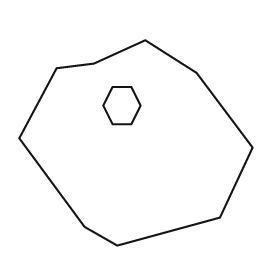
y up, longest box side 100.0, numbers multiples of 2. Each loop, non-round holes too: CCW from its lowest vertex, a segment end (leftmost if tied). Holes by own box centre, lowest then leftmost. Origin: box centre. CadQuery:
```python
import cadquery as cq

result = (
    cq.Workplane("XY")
    .moveTo(-8.0, -44.0)
    .lineTo(36.0, -32.0)
    .lineTo(50.0, -2.0)
    .lineTo(26.0, 30.0)
    .lineTo(4.0, 44.0)
    .lineTo(-18.0, 34.0)
    .lineTo(-34.0, 32.0)
    .lineTo(-50.0, 2.0)
    .lineTo(-22.0, -36.0)
    .close()
    .moveTo(-10.0, 8.0)
    .lineTo(-2.0, 8.0)
    .lineTo(2.0, 16.0)
    .lineTo(-2.0, 24.0)
    .lineTo(-10.0, 24.0)
    .lineTo(-14.0, 16.0)
    .close()
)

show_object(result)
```